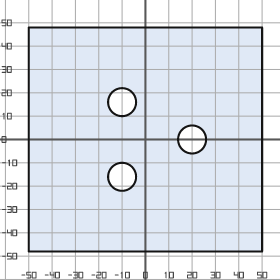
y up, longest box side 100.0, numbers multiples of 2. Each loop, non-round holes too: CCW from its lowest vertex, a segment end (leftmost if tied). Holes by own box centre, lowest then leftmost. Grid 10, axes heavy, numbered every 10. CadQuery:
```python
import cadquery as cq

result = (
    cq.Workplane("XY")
    .moveTo(-50.0, -48.0)
    .lineTo(50.0, -48.0)
    .lineTo(50.0, 48.0)
    .lineTo(-50.0, 48.0)
    .close()
    .moveTo(-10.0, -16.0)
    .circle(6.0)
    .moveTo(20.0, 0.0)
    .circle(6.0)
    .moveTo(-10.0, 16.0)
    .circle(6.0)
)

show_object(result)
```